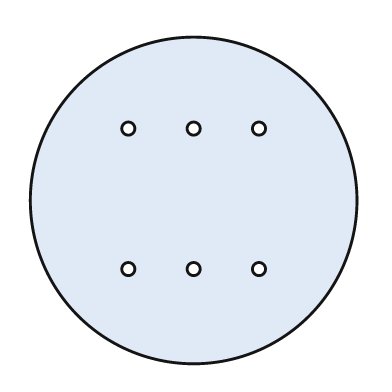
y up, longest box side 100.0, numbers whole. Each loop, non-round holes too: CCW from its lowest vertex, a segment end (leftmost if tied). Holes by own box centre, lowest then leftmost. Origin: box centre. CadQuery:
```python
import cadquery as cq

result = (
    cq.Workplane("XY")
    .moveTo(0.0, 0.0)
    .circle(50.0)
    .moveTo(-20.0, -21.0)
    .circle(2.0)
    .moveTo(0.0, -21.0)
    .circle(2.0)
    .moveTo(20.0, -21.0)
    .circle(2.0)
    .moveTo(-20.0, 22.0)
    .circle(2.0)
    .moveTo(0.0, 22.0)
    .circle(2.0)
    .moveTo(20.0, 22.0)
    .circle(2.0)
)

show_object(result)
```